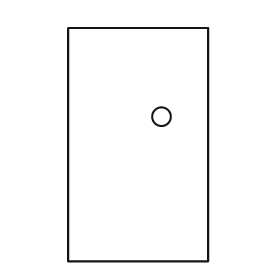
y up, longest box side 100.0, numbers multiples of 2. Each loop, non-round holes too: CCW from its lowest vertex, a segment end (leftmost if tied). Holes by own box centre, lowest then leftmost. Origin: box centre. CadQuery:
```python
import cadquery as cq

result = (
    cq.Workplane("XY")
    .moveTo(-30.0, -50.0)
    .lineTo(30.0, -50.0)
    .lineTo(30.0, 50.0)
    .lineTo(-30.0, 50.0)
    .close()
    .moveTo(10.0, 12.0)
    .circle(4.0)
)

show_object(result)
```